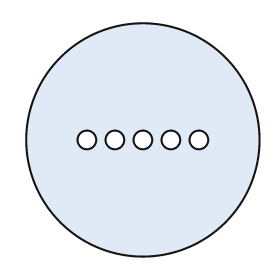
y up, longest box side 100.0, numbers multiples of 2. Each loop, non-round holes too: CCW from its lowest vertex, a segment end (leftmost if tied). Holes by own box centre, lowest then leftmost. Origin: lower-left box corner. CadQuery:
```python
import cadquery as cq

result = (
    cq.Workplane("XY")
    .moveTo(50.0, 50.0)
    .circle(50.0)
    .moveTo(26.0, 50.0)
    .circle(4.0)
    .moveTo(38.0, 50.0)
    .circle(4.0)
    .moveTo(50.0, 50.0)
    .circle(4.0)
    .moveTo(62.0, 50.0)
    .circle(4.0)
    .moveTo(74.0, 50.0)
    .circle(4.0)
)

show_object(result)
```